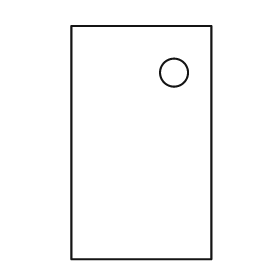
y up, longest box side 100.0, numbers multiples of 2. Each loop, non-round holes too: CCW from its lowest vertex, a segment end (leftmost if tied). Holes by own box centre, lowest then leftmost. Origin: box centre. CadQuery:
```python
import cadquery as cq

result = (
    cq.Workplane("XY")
    .moveTo(-30.0, -50.0)
    .lineTo(30.0, -50.0)
    .lineTo(30.0, 50.0)
    .lineTo(-30.0, 50.0)
    .close()
    .moveTo(14.0, 30.0)
    .circle(6.0)
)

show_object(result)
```